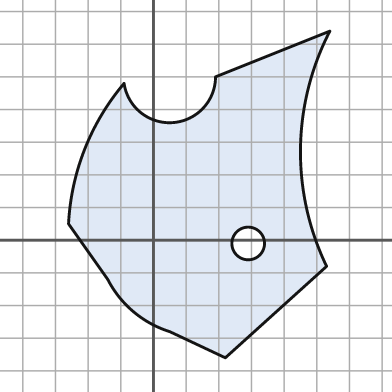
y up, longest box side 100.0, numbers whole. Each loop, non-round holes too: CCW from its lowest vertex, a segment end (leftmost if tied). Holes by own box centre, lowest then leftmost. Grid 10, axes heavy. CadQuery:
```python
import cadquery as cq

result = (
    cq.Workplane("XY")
    .moveTo(22.0, -36.0)
    .lineTo(53.0, -8.0)
    .threePointArc((45.0, 28.0), (54.0, 64.0))
    .lineTo(19.0, 50.0)
    .threePointArc((6.0, 36.0), (-9.0, 48.0))
    .threePointArc((-21.0, 28.0), (-26.0, 5.0))
    .lineTo(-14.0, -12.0)
    .threePointArc((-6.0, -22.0), (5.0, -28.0))
    .close()
    .moveTo(29.0, -1.0)
    .circle(5.0)
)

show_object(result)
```